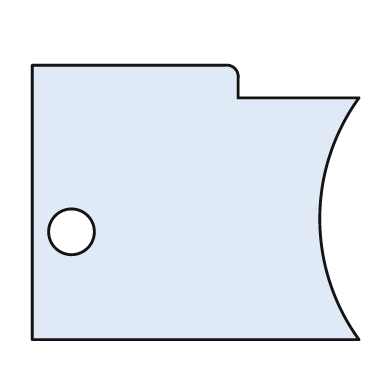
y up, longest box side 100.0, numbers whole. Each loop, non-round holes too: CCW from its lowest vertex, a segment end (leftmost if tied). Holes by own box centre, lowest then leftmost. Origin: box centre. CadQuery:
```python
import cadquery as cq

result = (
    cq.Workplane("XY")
    .moveTo(-50.0, -42.0)
    .lineTo(50.0, -42.0)
    .threePointArc((38.0, -5.0), (50.0, 32.0))
    .lineTo(13.0, 32.0)
    .lineTo(13.0, 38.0)
    .threePointArc((12.0, 41.0), (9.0, 42.0))
    .lineTo(-50.0, 42.0)
    .close()
    .moveTo(-38.0, -9.0)
    .circle(7.0)
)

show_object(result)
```